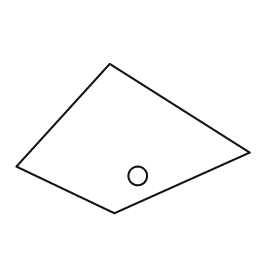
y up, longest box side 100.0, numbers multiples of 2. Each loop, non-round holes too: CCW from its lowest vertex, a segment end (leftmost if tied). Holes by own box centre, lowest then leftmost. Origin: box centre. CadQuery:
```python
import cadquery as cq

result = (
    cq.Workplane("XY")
    .moveTo(-8.0, -32.0)
    .lineTo(50.0, -6.0)
    .lineTo(-10.0, 32.0)
    .lineTo(-50.0, -12.0)
    .close()
    .moveTo(2.0, -16.0)
    .circle(4.0)
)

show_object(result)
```